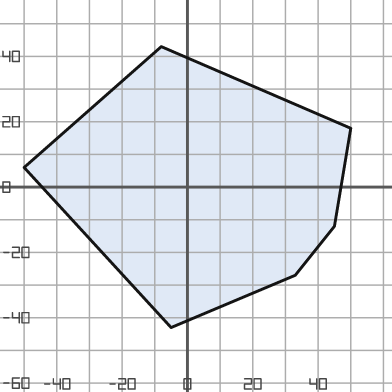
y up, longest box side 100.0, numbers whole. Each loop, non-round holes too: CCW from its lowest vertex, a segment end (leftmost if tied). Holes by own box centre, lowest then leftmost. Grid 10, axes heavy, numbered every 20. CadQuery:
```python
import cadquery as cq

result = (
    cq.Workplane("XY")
    .moveTo(-5.0, -43.0)
    .lineTo(33.0, -27.0)
    .lineTo(45.0, -12.0)
    .lineTo(50.0, 18.0)
    .lineTo(-8.0, 43.0)
    .lineTo(-50.0, 6.0)
    .close()
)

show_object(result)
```